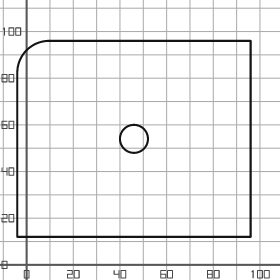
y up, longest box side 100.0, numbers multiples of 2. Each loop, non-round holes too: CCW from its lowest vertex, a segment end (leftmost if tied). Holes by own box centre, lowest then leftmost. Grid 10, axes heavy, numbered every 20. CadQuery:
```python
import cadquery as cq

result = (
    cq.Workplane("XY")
    .moveTo(-4.0, 12.0)
    .lineTo(96.0, 12.0)
    .lineTo(96.0, 96.0)
    .lineTo(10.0, 96.0)
    .threePointArc((0.0, 92.0), (-4.0, 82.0))
    .close()
    .moveTo(46.0, 54.0)
    .circle(6.0)
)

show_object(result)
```